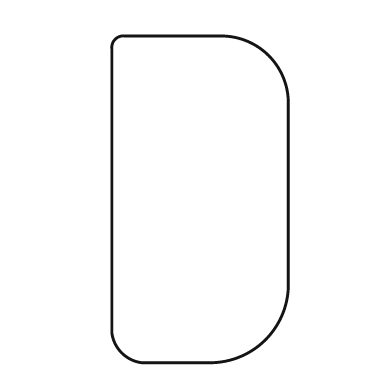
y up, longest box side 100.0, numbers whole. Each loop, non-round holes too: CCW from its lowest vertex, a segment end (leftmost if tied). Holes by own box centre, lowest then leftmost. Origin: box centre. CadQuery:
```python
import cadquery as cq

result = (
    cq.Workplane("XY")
    .moveTo(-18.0, -50.0)
    .lineTo(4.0, -50.0)
    .threePointArc((20.0, -43.0), (27.0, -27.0))
    .lineTo(27.0, 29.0)
    .threePointArc((21.0, 44.0), (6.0, 50.0))
    .lineTo(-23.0, 50.0)
    .threePointArc((-26.0, 49.0), (-27.0, 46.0))
    .lineTo(-27.0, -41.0)
    .threePointArc((-24.0, -47.0), (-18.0, -50.0))
    .close()
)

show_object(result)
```